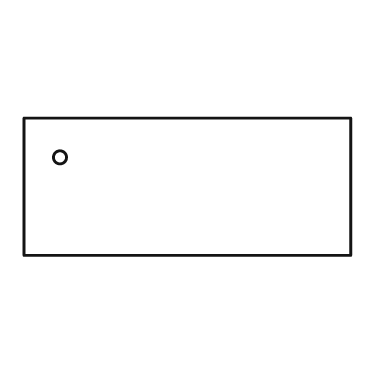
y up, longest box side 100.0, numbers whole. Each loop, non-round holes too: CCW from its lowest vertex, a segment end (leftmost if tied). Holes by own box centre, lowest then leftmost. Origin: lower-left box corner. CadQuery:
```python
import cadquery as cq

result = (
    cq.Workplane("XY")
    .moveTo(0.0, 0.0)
    .lineTo(100.0, 0.0)
    .lineTo(100.0, 42.0)
    .lineTo(0.0, 42.0)
    .close()
    .moveTo(11.0, 30.0)
    .circle(2.0)
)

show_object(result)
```